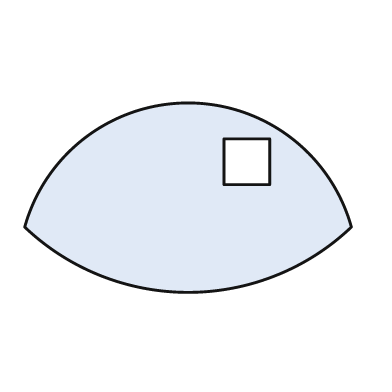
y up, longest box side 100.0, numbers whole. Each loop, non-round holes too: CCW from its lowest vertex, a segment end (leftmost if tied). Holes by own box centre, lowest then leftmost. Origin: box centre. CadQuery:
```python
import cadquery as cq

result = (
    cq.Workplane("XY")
    .moveTo(-50.0, -9.0)
    .threePointArc((0.0, -29.0), (50.0, -9.0))
    .threePointArc((0.0, 29.0), (-50.0, -9.0))
    .close()
    .moveTo(11.0, 4.0)
    .lineTo(25.0, 4.0)
    .lineTo(25.0, 18.0)
    .lineTo(11.0, 18.0)
    .close()
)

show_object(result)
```